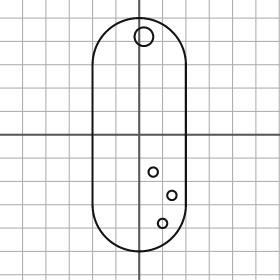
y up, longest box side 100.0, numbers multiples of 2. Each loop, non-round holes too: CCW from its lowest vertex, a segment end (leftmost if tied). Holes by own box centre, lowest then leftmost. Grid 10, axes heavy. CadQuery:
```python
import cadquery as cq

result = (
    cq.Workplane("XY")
    .moveTo(-20.0, -30.0)
    .threePointArc((0.0, -50.0), (20.0, -30.0))
    .lineTo(20.0, 30.0)
    .threePointArc((0.0, 50.0), (-20.0, 30.0))
    .close()
    .moveTo(10.0, -38.0)
    .circle(2.0)
    .moveTo(14.0, -26.0)
    .circle(2.0)
    .moveTo(6.0, -16.0)
    .circle(2.0)
    .moveTo(2.0, 42.0)
    .circle(4.0)
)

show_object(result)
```